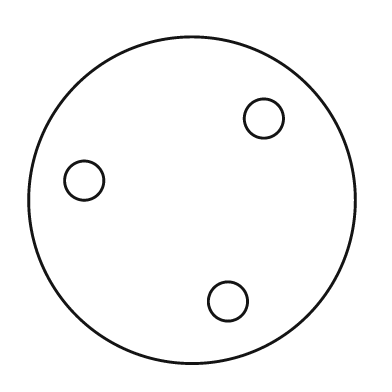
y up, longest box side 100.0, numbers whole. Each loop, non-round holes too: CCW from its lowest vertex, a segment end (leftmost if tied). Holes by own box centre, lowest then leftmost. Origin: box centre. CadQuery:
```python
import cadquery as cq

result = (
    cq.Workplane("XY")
    .moveTo(0.0, 0.0)
    .circle(50.0)
    .moveTo(11.0, -31.0)
    .circle(6.0)
    .moveTo(-33.0, 6.0)
    .circle(6.0)
    .moveTo(22.0, 25.0)
    .circle(6.0)
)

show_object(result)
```